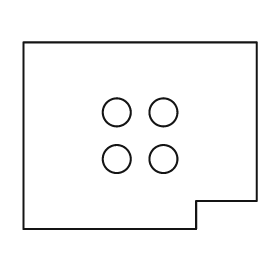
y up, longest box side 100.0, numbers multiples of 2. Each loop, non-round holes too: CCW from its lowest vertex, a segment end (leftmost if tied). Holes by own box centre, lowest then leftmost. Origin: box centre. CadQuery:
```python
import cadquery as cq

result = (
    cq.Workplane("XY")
    .moveTo(-50.0, -40.0)
    .lineTo(24.0, -40.0)
    .lineTo(24.0, -28.0)
    .lineTo(50.0, -28.0)
    .lineTo(50.0, 40.0)
    .lineTo(-50.0, 40.0)
    .close()
    .moveTo(-10.0, -10.0)
    .circle(6.0)
    .moveTo(10.0, -10.0)
    .circle(6.0)
    .moveTo(-10.0, 10.0)
    .circle(6.0)
    .moveTo(10.0, 10.0)
    .circle(6.0)
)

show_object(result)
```